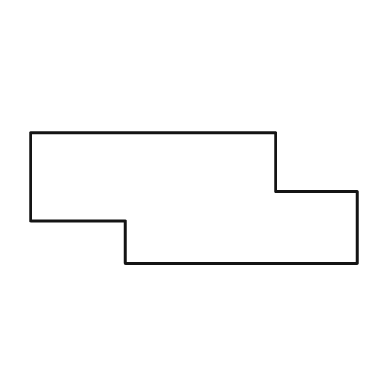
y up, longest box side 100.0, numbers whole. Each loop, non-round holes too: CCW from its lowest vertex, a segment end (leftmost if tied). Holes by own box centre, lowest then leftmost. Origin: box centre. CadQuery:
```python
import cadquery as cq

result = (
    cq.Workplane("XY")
    .moveTo(-21.0, -20.0)
    .lineTo(50.0, -20.0)
    .lineTo(50.0, 2.0)
    .lineTo(25.0, 2.0)
    .lineTo(25.0, 20.0)
    .lineTo(-50.0, 20.0)
    .lineTo(-50.0, -7.0)
    .lineTo(-21.0, -7.0)
    .close()
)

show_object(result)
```